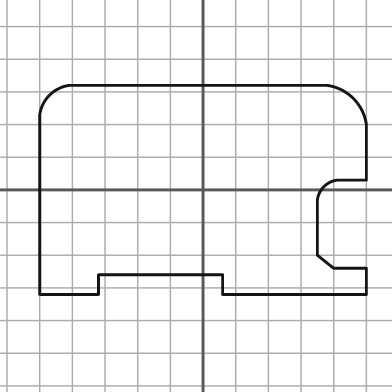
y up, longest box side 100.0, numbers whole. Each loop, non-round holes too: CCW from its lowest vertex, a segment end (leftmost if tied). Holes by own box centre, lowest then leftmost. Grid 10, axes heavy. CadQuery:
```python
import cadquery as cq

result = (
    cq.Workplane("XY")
    .moveTo(-50.0, -32.0)
    .lineTo(-32.0, -32.0)
    .lineTo(-32.0, -26.0)
    .lineTo(6.0, -26.0)
    .lineTo(6.0, -32.0)
    .lineTo(50.0, -32.0)
    .lineTo(50.0, -24.0)
    .lineTo(40.0, -24.0)
    .lineTo(35.0, -20.0)
    .lineTo(35.0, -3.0)
    .threePointArc((37.0, 1.0), (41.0, 3.0))
    .lineTo(50.0, 3.0)
    .lineTo(50.0, 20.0)
    .threePointArc((46.0, 28.0), (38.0, 32.0))
    .lineTo(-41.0, 32.0)
    .threePointArc((-47.0, 29.0), (-50.0, 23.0))
    .close()
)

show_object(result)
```